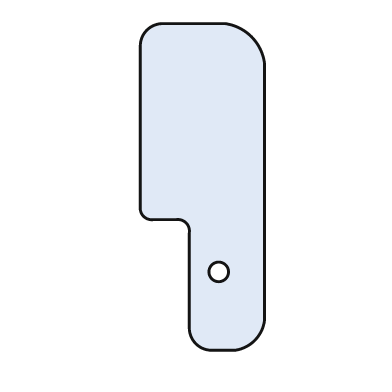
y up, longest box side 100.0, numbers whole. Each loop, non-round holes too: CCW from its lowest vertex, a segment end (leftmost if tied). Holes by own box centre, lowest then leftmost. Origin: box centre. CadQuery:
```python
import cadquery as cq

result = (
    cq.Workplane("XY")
    .moveTo(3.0, -50.0)
    .lineTo(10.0, -50.0)
    .threePointArc((16.0, -47.0), (19.0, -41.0))
    .lineTo(19.0, 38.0)
    .threePointArc((15.0, 46.0), (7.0, 50.0))
    .lineTo(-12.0, 50.0)
    .threePointArc((-17.0, 48.0), (-19.0, 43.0))
    .lineTo(-19.0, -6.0)
    .threePointArc((-18.0, -9.0), (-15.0, -10.0))
    .lineTo(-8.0, -10.0)
    .threePointArc((-5.0, -11.0), (-4.0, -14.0))
    .lineTo(-4.0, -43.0)
    .threePointArc((-2.0, -48.0), (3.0, -50.0))
    .close()
    .moveTo(5.0, -26.0)
    .circle(3.0)
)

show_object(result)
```